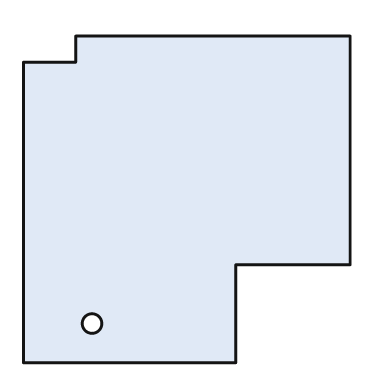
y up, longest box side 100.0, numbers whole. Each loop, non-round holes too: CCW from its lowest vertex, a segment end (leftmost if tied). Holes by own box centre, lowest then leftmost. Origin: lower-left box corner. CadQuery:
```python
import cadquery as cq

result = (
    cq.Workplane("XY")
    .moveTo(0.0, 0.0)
    .lineTo(65.0, 0.0)
    .lineTo(65.0, 30.0)
    .lineTo(100.0, 30.0)
    .lineTo(100.0, 100.0)
    .lineTo(16.0, 100.0)
    .lineTo(16.0, 92.0)
    .lineTo(0.0, 92.0)
    .close()
    .moveTo(21.0, 12.0)
    .circle(3.0)
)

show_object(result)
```